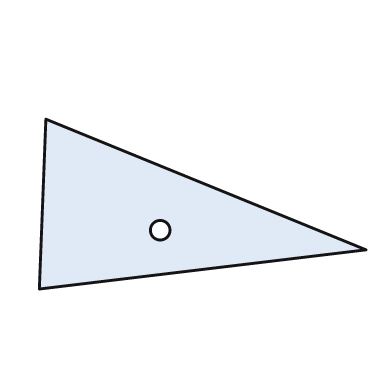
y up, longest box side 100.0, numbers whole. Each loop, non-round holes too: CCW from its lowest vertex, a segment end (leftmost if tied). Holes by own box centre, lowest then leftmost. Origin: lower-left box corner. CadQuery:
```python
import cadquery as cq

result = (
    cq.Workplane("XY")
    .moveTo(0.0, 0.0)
    .lineTo(100.0, 12.0)
    .lineTo(2.0, 52.0)
    .close()
    .moveTo(37.0, 18.0)
    .circle(3.0)
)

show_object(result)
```